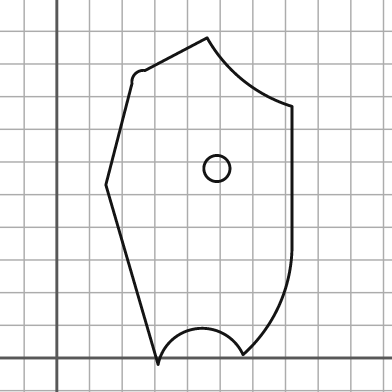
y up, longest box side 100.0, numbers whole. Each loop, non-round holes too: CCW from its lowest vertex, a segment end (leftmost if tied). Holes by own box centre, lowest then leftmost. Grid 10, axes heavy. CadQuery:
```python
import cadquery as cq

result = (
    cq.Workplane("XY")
    .moveTo(31.0, -2.0)
    .threePointArc((43.0, 9.0), (57.0, 1.0))
    .threePointArc((68.0, 16.0), (72.0, 34.0))
    .lineTo(72.0, 77.0)
    .threePointArc((57.0, 85.0), (46.0, 98.0))
    .lineTo(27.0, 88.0)
    .threePointArc((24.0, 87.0), (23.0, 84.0))
    .lineTo(15.0, 53.0)
    .close()
    .moveTo(49.0, 58.0)
    .circle(4.0)
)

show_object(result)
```